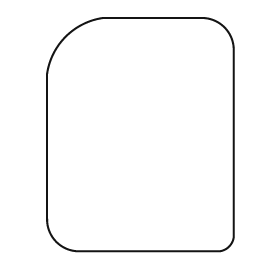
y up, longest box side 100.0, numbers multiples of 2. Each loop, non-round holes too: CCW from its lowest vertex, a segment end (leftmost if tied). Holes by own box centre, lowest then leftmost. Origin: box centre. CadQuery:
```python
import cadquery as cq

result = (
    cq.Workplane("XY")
    .moveTo(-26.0, -50.0)
    .lineTo(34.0, -50.0)
    .threePointArc((38.0, -48.0), (40.0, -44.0))
    .lineTo(40.0, 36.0)
    .threePointArc((36.0, 46.0), (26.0, 50.0))
    .lineTo(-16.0, 50.0)
    .threePointArc((-32.0, 42.0), (-40.0, 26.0))
    .lineTo(-40.0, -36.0)
    .threePointArc((-36.0, -46.0), (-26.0, -50.0))
    .close()
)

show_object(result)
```